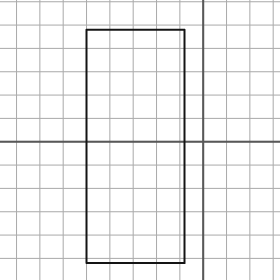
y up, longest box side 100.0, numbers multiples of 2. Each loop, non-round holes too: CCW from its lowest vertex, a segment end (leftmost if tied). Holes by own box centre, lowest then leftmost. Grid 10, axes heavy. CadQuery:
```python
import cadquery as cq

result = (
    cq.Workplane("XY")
    .moveTo(-50.0, -52.0)
    .lineTo(-8.0, -52.0)
    .lineTo(-8.0, 48.0)
    .lineTo(-50.0, 48.0)
    .close()
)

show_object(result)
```